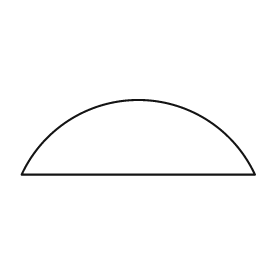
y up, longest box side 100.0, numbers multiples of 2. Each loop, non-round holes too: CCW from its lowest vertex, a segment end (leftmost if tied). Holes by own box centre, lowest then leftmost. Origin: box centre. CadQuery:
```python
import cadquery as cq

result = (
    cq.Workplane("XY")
    .moveTo(-50.0, -16.0)
    .lineTo(50.0, -16.0)
    .threePointArc((0.0, 16.0), (-50.0, -16.0))
    .close()
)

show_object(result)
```